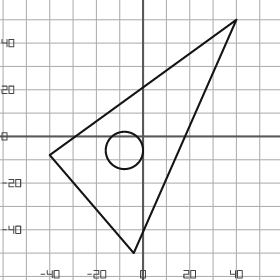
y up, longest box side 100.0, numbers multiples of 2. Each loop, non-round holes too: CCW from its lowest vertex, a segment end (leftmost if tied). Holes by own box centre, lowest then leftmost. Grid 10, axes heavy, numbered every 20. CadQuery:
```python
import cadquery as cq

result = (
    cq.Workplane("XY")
    .moveTo(-4.0, -50.0)
    .lineTo(40.0, 50.0)
    .lineTo(-40.0, -8.0)
    .close()
    .moveTo(-8.0, -6.0)
    .circle(8.0)
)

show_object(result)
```